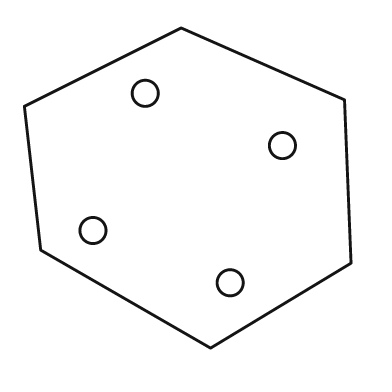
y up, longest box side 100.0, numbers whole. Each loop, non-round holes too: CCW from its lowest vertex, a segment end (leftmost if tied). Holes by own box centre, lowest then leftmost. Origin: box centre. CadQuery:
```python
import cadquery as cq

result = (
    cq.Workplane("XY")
    .moveTo(7.0, -49.0)
    .lineTo(50.0, -23.0)
    .lineTo(48.0, 27.0)
    .lineTo(-2.0, 49.0)
    .lineTo(-50.0, 25.0)
    .lineTo(-45.0, -19.0)
    .close()
    .moveTo(13.0, -29.0)
    .circle(4.0)
    .moveTo(-29.0, -13.0)
    .circle(4.0)
    .moveTo(29.0, 13.0)
    .circle(4.0)
    .moveTo(-13.0, 29.0)
    .circle(4.0)
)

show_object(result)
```